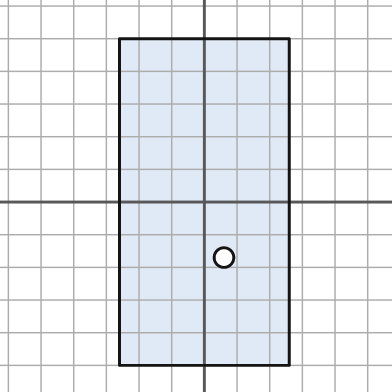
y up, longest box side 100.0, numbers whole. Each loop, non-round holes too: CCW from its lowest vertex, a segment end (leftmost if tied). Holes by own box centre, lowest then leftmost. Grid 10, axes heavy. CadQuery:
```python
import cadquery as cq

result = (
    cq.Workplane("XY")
    .moveTo(-26.0, -50.0)
    .lineTo(26.0, -50.0)
    .lineTo(26.0, 50.0)
    .lineTo(-26.0, 50.0)
    .close()
    .moveTo(6.0, -17.0)
    .circle(3.0)
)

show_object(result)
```